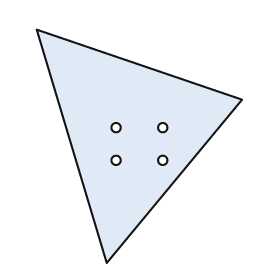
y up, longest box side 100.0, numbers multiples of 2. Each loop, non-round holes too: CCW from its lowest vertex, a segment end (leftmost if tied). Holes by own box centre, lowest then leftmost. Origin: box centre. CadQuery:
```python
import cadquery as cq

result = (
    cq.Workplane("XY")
    .moveTo(-14.0, -50.0)
    .lineTo(44.0, 20.0)
    .lineTo(-44.0, 50.0)
    .close()
    .moveTo(-10.0, -6.0)
    .circle(2.0)
    .moveTo(10.0, -6.0)
    .circle(2.0)
    .moveTo(-10.0, 8.0)
    .circle(2.0)
    .moveTo(10.0, 8.0)
    .circle(2.0)
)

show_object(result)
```